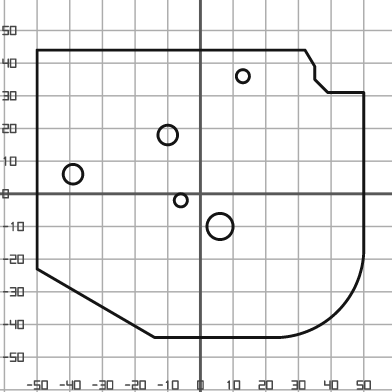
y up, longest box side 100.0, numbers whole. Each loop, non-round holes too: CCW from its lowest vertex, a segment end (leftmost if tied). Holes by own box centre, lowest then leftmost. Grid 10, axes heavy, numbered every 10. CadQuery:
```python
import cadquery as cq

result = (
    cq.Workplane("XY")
    .moveTo(-14.0, -44.0)
    .lineTo(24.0, -44.0)
    .threePointArc((42.0, -36.0), (50.0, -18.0))
    .lineTo(50.0, 31.0)
    .lineTo(39.0, 31.0)
    .lineTo(35.0, 35.0)
    .lineTo(35.0, 39.0)
    .lineTo(32.0, 44.0)
    .lineTo(-50.0, 44.0)
    .lineTo(-50.0, -23.0)
    .close()
    .moveTo(6.0, -10.0)
    .circle(4.0)
    .moveTo(-6.0, -2.0)
    .circle(2.0)
    .moveTo(-39.0, 6.0)
    .circle(3.0)
    .moveTo(-10.0, 18.0)
    .circle(3.0)
    .moveTo(13.0, 36.0)
    .circle(2.0)
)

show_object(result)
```